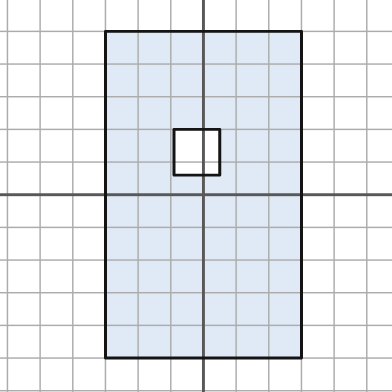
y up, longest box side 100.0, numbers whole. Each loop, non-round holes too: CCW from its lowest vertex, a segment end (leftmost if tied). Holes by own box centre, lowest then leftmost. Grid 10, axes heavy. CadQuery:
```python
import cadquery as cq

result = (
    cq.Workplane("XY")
    .moveTo(-30.0, -50.0)
    .lineTo(30.0, -50.0)
    .lineTo(30.0, 50.0)
    .lineTo(-30.0, 50.0)
    .close()
    .moveTo(-9.0, 6.0)
    .lineTo(5.0, 6.0)
    .lineTo(5.0, 20.0)
    .lineTo(-9.0, 20.0)
    .close()
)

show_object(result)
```